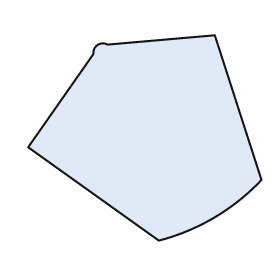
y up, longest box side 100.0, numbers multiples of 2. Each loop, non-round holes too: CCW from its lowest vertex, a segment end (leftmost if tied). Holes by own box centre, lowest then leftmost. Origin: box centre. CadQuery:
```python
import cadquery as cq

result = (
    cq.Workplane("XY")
    .moveTo(6.0, -44.0)
    .threePointArc((30.0, -34.0), (50.0, -18.0))
    .lineTo(30.0, 44.0)
    .lineTo(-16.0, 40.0)
    .threePointArc((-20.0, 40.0), (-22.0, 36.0))
    .lineTo(-50.0, -4.0)
    .close()
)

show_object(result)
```